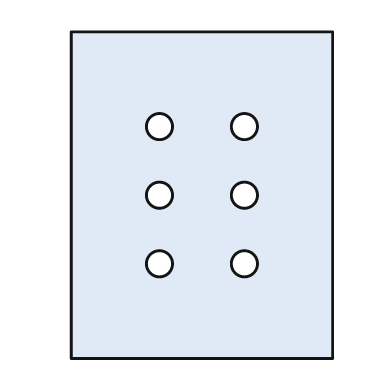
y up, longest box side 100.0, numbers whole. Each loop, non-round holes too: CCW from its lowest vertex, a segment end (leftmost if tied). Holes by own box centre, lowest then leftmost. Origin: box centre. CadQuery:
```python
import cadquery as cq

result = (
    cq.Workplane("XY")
    .moveTo(-40.0, -50.0)
    .lineTo(40.0, -50.0)
    .lineTo(40.0, 50.0)
    .lineTo(-40.0, 50.0)
    .close()
    .moveTo(-13.0, -21.0)
    .circle(4.0)
    .moveTo(13.0, -21.0)
    .circle(4.0)
    .moveTo(-13.0, 0.0)
    .circle(4.0)
    .moveTo(13.0, 0.0)
    .circle(4.0)
    .moveTo(-13.0, 21.0)
    .circle(4.0)
    .moveTo(13.0, 21.0)
    .circle(4.0)
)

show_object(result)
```